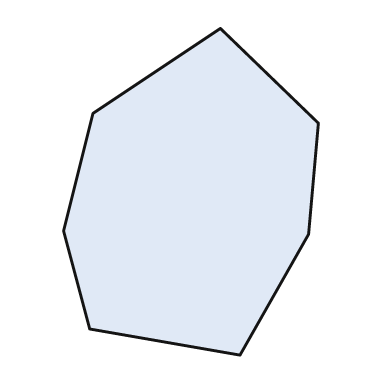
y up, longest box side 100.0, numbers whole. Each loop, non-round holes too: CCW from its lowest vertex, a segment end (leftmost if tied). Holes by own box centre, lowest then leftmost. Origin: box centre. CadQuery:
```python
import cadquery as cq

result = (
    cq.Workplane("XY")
    .moveTo(15.0, -50.0)
    .lineTo(36.0, -13.0)
    .lineTo(39.0, 21.0)
    .lineTo(9.0, 50.0)
    .lineTo(-30.0, 24.0)
    .lineTo(-39.0, -12.0)
    .lineTo(-31.0, -42.0)
    .close()
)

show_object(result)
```